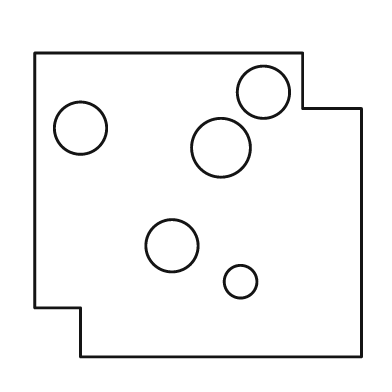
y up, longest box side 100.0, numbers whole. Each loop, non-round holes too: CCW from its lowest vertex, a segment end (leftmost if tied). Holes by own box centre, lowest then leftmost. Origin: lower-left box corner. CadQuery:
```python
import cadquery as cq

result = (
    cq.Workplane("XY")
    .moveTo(14.0, 0.0)
    .lineTo(100.0, 0.0)
    .lineTo(100.0, 76.0)
    .lineTo(82.0, 76.0)
    .lineTo(82.0, 93.0)
    .lineTo(0.0, 93.0)
    .lineTo(0.0, 15.0)
    .lineTo(14.0, 15.0)
    .close()
    .moveTo(63.0, 23.0)
    .circle(5.0)
    .moveTo(42.0, 34.0)
    .circle(8.0)
    .moveTo(57.0, 64.0)
    .circle(9.0)
    .moveTo(14.0, 70.0)
    .circle(8.0)
    .moveTo(70.0, 81.0)
    .circle(8.0)
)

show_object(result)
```